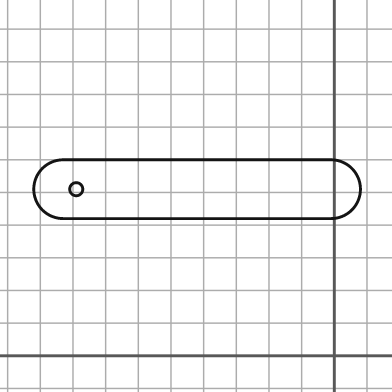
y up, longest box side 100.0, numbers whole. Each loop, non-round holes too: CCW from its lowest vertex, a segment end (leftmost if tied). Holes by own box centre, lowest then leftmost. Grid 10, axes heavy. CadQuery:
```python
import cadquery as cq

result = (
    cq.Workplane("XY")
    .moveTo(-83.0, 42.0)
    .lineTo(-1.0, 42.0)
    .threePointArc((8.0, 51.0), (-1.0, 60.0))
    .lineTo(-83.0, 60.0)
    .threePointArc((-92.0, 51.0), (-83.0, 42.0))
    .close()
    .moveTo(-79.0, 51.0)
    .circle(2.0)
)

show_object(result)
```